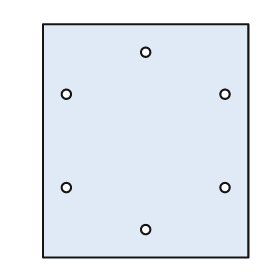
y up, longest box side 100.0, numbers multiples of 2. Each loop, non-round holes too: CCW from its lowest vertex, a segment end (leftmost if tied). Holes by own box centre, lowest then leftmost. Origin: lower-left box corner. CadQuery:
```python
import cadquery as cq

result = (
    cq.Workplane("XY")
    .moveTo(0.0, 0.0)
    .lineTo(88.0, 0.0)
    .lineTo(88.0, 100.0)
    .lineTo(0.0, 100.0)
    .close()
    .moveTo(44.0, 12.0)
    .circle(2.0)
    .moveTo(10.0, 30.0)
    .circle(2.0)
    .moveTo(78.0, 30.0)
    .circle(2.0)
    .moveTo(10.0, 70.0)
    .circle(2.0)
    .moveTo(78.0, 70.0)
    .circle(2.0)
    .moveTo(44.0, 88.0)
    .circle(2.0)
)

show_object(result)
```